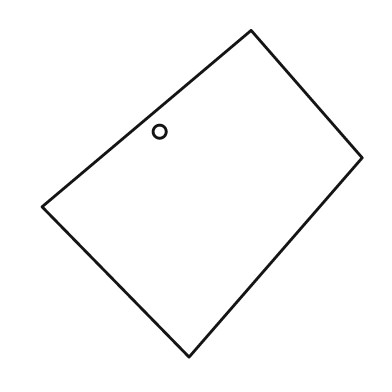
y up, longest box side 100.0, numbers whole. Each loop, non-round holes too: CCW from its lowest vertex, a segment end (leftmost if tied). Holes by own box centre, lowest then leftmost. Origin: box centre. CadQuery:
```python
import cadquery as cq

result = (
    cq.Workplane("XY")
    .moveTo(-4.0, -50.0)
    .lineTo(49.0, 11.0)
    .lineTo(15.0, 50.0)
    .lineTo(-49.0, -4.0)
    .close()
    .moveTo(-13.0, 19.0)
    .circle(2.0)
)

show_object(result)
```